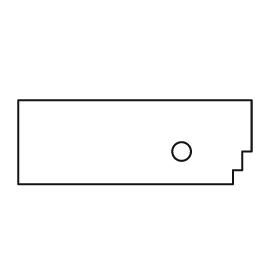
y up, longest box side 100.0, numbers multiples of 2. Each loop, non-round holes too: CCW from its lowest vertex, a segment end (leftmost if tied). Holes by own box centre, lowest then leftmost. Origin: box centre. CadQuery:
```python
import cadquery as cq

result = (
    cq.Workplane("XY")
    .moveTo(-50.0, -18.0)
    .lineTo(42.0, -18.0)
    .lineTo(42.0, -12.0)
    .lineTo(46.0, -12.0)
    .lineTo(46.0, -4.0)
    .lineTo(50.0, -4.0)
    .lineTo(50.0, 18.0)
    .lineTo(-50.0, 18.0)
    .close()
    .moveTo(20.0, -4.0)
    .circle(4.0)
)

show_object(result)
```